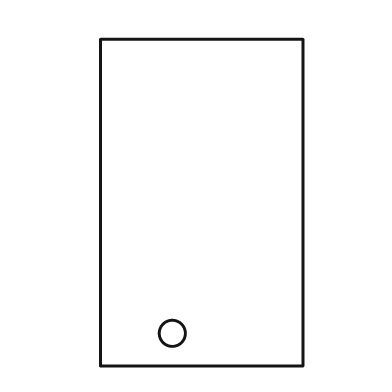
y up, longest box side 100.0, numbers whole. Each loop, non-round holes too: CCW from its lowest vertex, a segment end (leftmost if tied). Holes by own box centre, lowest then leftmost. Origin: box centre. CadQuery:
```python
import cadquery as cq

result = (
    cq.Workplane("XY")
    .moveTo(-31.0, -50.0)
    .lineTo(31.0, -50.0)
    .lineTo(31.0, 50.0)
    .lineTo(-31.0, 50.0)
    .close()
    .moveTo(-9.0, -40.0)
    .circle(4.0)
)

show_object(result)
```